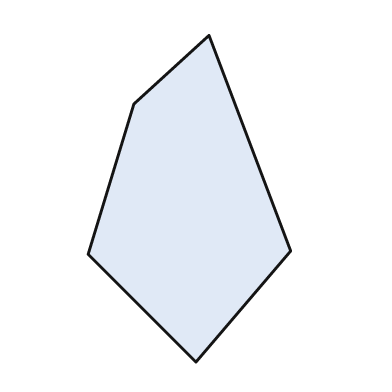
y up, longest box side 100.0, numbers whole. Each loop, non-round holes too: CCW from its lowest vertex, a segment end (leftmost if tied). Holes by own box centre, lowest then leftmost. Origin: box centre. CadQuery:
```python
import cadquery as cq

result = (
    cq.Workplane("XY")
    .moveTo(2.0, -50.0)
    .lineTo(31.0, -16.0)
    .lineTo(6.0, 50.0)
    .lineTo(-17.0, 29.0)
    .lineTo(-31.0, -17.0)
    .close()
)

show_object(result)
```